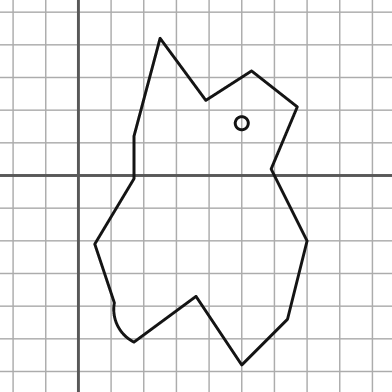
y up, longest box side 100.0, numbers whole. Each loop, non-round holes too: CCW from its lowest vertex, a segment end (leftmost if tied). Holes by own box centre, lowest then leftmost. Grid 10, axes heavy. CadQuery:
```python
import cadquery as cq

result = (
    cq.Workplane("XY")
    .moveTo(50.0, -58.0)
    .lineTo(64.0, -44.0)
    .lineTo(70.0, -20.0)
    .lineTo(59.0, 2.0)
    .lineTo(67.0, 21.0)
    .lineTo(53.0, 32.0)
    .lineTo(39.0, 23.0)
    .lineTo(25.0, 42.0)
    .lineTo(17.0, 12.0)
    .lineTo(17.0, -1.0)
    .lineTo(5.0, -21.0)
    .lineTo(11.0, -39.0)
    .threePointArc((12.0, -46.0), (17.0, -51.0))
    .lineTo(36.0, -37.0)
    .close()
    .moveTo(50.0, 16.0)
    .circle(2.0)
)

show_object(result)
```